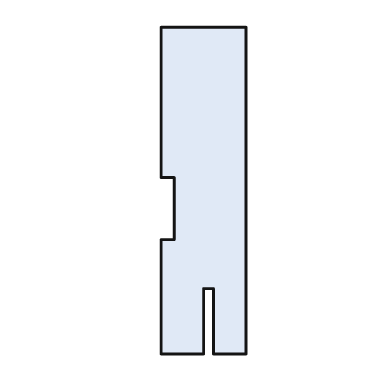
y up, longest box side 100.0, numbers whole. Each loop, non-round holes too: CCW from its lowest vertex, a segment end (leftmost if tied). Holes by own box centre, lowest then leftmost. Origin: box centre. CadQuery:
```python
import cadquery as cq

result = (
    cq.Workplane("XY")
    .moveTo(-13.0, -50.0)
    .lineTo(0.0, -50.0)
    .lineTo(0.0, -30.0)
    .lineTo(3.0, -30.0)
    .lineTo(3.0, -50.0)
    .lineTo(13.0, -50.0)
    .lineTo(13.0, 50.0)
    .lineTo(-13.0, 50.0)
    .lineTo(-13.0, 4.0)
    .lineTo(-9.0, 4.0)
    .lineTo(-9.0, -15.0)
    .lineTo(-13.0, -15.0)
    .close()
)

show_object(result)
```